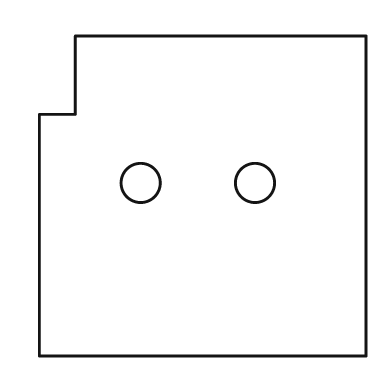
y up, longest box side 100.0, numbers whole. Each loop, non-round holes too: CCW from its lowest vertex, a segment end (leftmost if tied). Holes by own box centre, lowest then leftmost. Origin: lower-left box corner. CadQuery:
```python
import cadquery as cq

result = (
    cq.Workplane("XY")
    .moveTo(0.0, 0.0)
    .lineTo(100.0, 0.0)
    .lineTo(100.0, 98.0)
    .lineTo(11.0, 98.0)
    .lineTo(11.0, 74.0)
    .lineTo(0.0, 74.0)
    .close()
    .moveTo(31.0, 53.0)
    .circle(6.0)
    .moveTo(66.0, 53.0)
    .circle(6.0)
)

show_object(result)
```